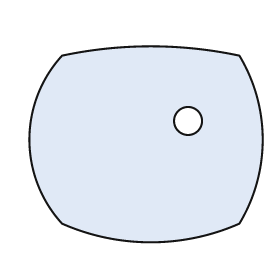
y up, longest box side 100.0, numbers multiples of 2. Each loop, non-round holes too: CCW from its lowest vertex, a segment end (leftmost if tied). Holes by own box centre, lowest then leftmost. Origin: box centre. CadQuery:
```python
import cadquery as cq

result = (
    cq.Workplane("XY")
    .moveTo(-36.0, -34.0)
    .threePointArc((2.0, -42.0), (40.0, -34.0))
    .threePointArc((50.0, 2.0), (40.0, 38.0))
    .threePointArc((2.0, 42.0), (-36.0, 38.0))
    .threePointArc((-50.0, 2.0), (-36.0, -34.0))
    .close()
    .moveTo(18.0, 10.0)
    .circle(6.0)
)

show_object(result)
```